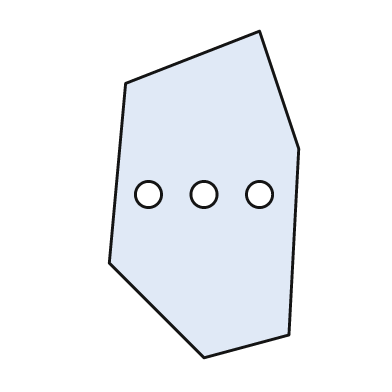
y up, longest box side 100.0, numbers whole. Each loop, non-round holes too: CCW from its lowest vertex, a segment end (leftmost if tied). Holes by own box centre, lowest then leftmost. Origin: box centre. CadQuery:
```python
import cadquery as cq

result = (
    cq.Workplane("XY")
    .moveTo(0.0, -50.0)
    .lineTo(26.0, -43.0)
    .lineTo(29.0, 14.0)
    .lineTo(17.0, 50.0)
    .lineTo(-24.0, 34.0)
    .lineTo(-29.0, -21.0)
    .close()
    .moveTo(-17.0, 0.0)
    .circle(4.0)
    .moveTo(0.0, 0.0)
    .circle(4.0)
    .moveTo(17.0, 0.0)
    .circle(4.0)
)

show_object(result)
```